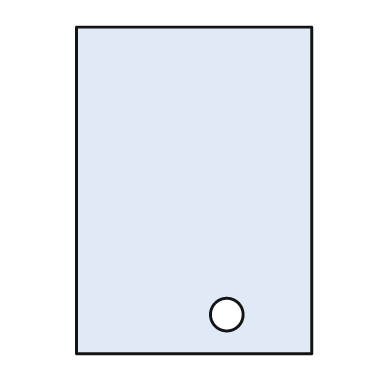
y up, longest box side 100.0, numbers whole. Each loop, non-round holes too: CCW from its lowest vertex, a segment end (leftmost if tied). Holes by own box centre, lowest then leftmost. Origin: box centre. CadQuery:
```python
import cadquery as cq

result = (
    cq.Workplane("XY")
    .moveTo(-36.0, -50.0)
    .lineTo(36.0, -50.0)
    .lineTo(36.0, 50.0)
    .lineTo(-36.0, 50.0)
    .close()
    .moveTo(10.0, -38.0)
    .circle(5.0)
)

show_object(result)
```